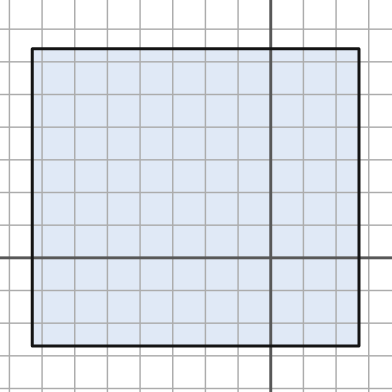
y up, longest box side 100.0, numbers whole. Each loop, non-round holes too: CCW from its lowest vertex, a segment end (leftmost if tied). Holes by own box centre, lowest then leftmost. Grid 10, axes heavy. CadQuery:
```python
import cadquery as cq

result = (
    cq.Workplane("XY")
    .moveTo(-73.0, -27.0)
    .lineTo(27.0, -27.0)
    .lineTo(27.0, 64.0)
    .lineTo(-73.0, 64.0)
    .close()
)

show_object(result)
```